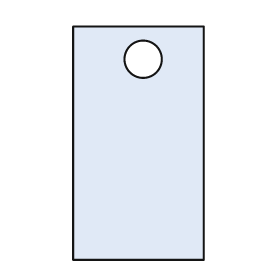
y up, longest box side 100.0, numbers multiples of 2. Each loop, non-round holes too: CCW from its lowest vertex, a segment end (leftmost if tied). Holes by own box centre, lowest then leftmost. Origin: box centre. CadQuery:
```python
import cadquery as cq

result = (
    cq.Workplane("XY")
    .moveTo(-28.0, -50.0)
    .lineTo(28.0, -50.0)
    .lineTo(28.0, 50.0)
    .lineTo(-28.0, 50.0)
    .close()
    .moveTo(2.0, 36.0)
    .circle(8.0)
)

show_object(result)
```